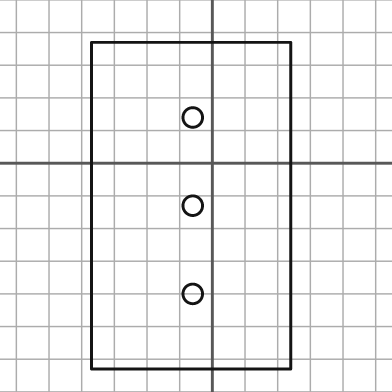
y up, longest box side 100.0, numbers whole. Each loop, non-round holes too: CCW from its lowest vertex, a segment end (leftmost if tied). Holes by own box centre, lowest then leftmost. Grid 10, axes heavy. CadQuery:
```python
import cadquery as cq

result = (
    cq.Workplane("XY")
    .moveTo(-37.0, -63.0)
    .lineTo(24.0, -63.0)
    .lineTo(24.0, 37.0)
    .lineTo(-37.0, 37.0)
    .close()
    .moveTo(-6.0, -40.0)
    .circle(3.0)
    .moveTo(-6.0, -13.0)
    .circle(3.0)
    .moveTo(-6.0, 14.0)
    .circle(3.0)
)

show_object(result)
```